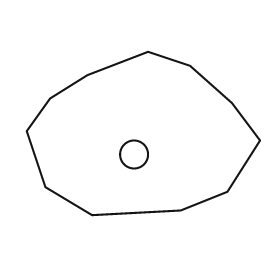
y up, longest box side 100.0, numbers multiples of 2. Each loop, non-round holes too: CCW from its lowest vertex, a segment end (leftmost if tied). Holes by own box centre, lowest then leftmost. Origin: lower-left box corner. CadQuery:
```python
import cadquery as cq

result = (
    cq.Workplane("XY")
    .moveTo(28.0, 0.0)
    .lineTo(66.0, 2.0)
    .lineTo(86.0, 10.0)
    .lineTo(100.0, 32.0)
    .lineTo(88.0, 48.0)
    .lineTo(70.0, 64.0)
    .lineTo(52.0, 70.0)
    .lineTo(26.0, 60.0)
    .lineTo(10.0, 50.0)
    .lineTo(0.0, 36.0)
    .lineTo(8.0, 12.0)
    .close()
    .moveTo(46.0, 26.0)
    .circle(6.0)
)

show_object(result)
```